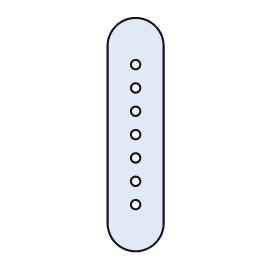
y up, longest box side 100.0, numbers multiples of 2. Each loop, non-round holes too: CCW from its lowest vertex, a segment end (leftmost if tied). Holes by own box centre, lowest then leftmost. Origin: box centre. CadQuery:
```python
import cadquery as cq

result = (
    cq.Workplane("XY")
    .moveTo(-12.0, -38.0)
    .threePointArc((0.0, -50.0), (12.0, -38.0))
    .lineTo(12.0, 38.0)
    .threePointArc((0.0, 50.0), (-12.0, 38.0))
    .close()
    .moveTo(0.0, -30.0)
    .circle(2.0)
    .moveTo(0.0, -20.0)
    .circle(2.0)
    .moveTo(0.0, -10.0)
    .circle(2.0)
    .moveTo(0.0, 0.0)
    .circle(2.0)
    .moveTo(0.0, 10.0)
    .circle(2.0)
    .moveTo(0.0, 20.0)
    .circle(2.0)
    .moveTo(0.0, 30.0)
    .circle(2.0)
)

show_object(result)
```